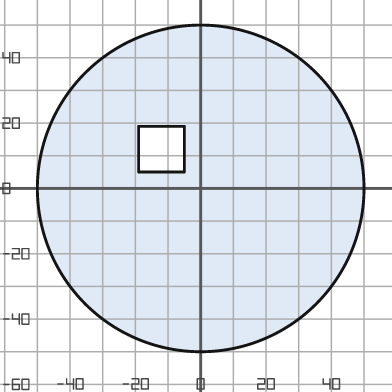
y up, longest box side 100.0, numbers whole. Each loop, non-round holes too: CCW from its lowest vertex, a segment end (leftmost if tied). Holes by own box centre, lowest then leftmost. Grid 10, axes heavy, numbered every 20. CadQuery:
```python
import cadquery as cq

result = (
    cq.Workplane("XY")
    .moveTo(0.0, 0.0)
    .circle(50.0)
    .moveTo(-19.0, 5.0)
    .lineTo(-5.0, 5.0)
    .lineTo(-5.0, 19.0)
    .lineTo(-19.0, 19.0)
    .close()
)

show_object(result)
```